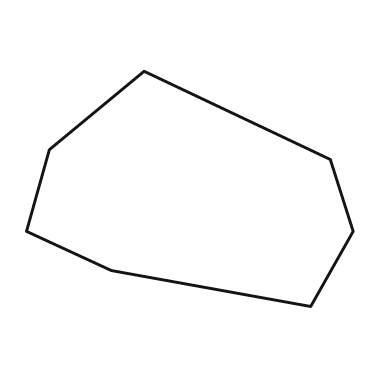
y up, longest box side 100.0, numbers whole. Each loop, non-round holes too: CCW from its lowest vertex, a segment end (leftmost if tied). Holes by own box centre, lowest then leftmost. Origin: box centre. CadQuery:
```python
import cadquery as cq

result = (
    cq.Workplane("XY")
    .moveTo(37.0, -36.0)
    .lineTo(50.0, -13.0)
    .lineTo(43.0, 9.0)
    .lineTo(-14.0, 36.0)
    .lineTo(-43.0, 12.0)
    .lineTo(-50.0, -13.0)
    .lineTo(-24.0, -25.0)
    .close()
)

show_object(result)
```